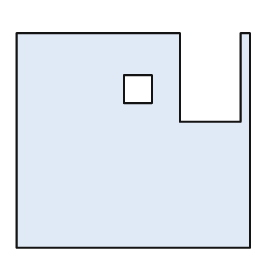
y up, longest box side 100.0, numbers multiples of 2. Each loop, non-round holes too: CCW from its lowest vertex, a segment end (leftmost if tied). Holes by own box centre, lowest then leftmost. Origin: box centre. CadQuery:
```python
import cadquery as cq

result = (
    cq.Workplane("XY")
    .moveTo(-50.0, -46.0)
    .lineTo(50.0, -46.0)
    .lineTo(50.0, 46.0)
    .lineTo(46.0, 46.0)
    .lineTo(46.0, 8.0)
    .lineTo(20.0, 8.0)
    .lineTo(20.0, 46.0)
    .lineTo(-50.0, 46.0)
    .close()
    .moveTo(-4.0, 16.0)
    .lineTo(8.0, 16.0)
    .lineTo(8.0, 28.0)
    .lineTo(-4.0, 28.0)
    .close()
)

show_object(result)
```